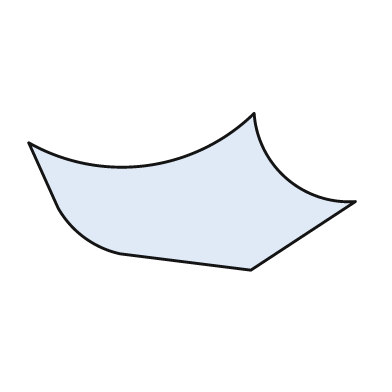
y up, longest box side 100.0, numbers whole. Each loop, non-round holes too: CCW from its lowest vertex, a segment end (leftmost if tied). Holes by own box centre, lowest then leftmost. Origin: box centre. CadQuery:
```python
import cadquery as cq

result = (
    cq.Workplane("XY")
    .moveTo(18.0, -24.0)
    .lineTo(50.0, -3.0)
    .threePointArc((29.0, 4.0), (19.0, 24.0))
    .threePointArc((-14.0, 8.0), (-50.0, 15.0))
    .lineTo(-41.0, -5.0)
    .threePointArc((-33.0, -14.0), (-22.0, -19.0))
    .close()
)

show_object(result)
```